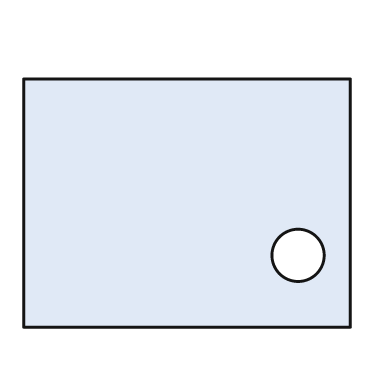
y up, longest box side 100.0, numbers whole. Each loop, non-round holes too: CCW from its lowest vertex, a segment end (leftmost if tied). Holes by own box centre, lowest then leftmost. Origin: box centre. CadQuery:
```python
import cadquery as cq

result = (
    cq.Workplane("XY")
    .moveTo(-50.0, -38.0)
    .lineTo(50.0, -38.0)
    .lineTo(50.0, 38.0)
    .lineTo(-50.0, 38.0)
    .close()
    .moveTo(34.0, -16.0)
    .circle(8.0)
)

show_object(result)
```